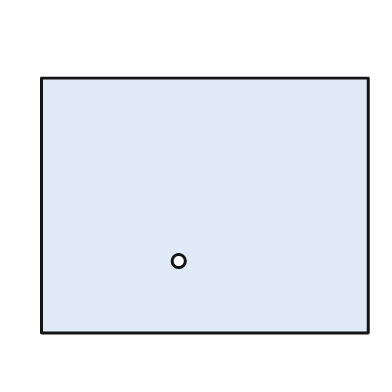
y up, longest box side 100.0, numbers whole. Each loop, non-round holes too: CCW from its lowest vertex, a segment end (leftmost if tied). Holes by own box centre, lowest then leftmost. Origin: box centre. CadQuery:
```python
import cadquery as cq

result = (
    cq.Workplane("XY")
    .moveTo(-50.0, -39.0)
    .lineTo(50.0, -39.0)
    .lineTo(50.0, 39.0)
    .lineTo(-50.0, 39.0)
    .close()
    .moveTo(-8.0, -17.0)
    .circle(2.0)
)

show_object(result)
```